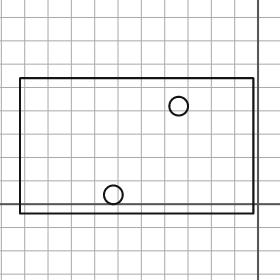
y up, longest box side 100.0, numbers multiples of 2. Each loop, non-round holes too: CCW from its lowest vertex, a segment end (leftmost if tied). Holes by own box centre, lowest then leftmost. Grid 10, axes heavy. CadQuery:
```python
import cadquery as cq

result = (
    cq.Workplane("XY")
    .moveTo(-102.0, -4.0)
    .lineTo(-2.0, -4.0)
    .lineTo(-2.0, 54.0)
    .lineTo(-102.0, 54.0)
    .close()
    .moveTo(-62.0, 4.0)
    .circle(4.0)
    .moveTo(-34.0, 42.0)
    .circle(4.0)
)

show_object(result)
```